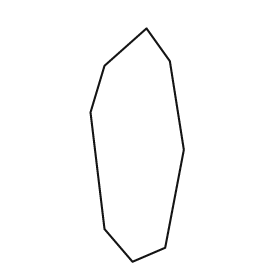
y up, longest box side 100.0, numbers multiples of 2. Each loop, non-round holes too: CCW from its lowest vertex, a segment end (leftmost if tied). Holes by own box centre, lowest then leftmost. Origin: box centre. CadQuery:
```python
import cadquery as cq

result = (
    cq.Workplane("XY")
    .moveTo(-2.0, -50.0)
    .lineTo(12.0, -44.0)
    .lineTo(20.0, -2.0)
    .lineTo(14.0, 36.0)
    .lineTo(4.0, 50.0)
    .lineTo(-14.0, 34.0)
    .lineTo(-20.0, 14.0)
    .lineTo(-14.0, -36.0)
    .close()
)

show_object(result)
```